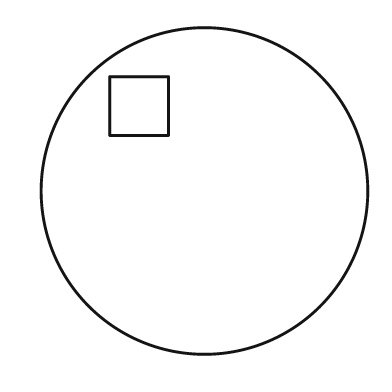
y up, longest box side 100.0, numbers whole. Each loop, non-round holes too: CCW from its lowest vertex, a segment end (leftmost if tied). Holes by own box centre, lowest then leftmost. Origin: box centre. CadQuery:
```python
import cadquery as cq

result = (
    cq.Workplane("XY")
    .moveTo(0.0, 0.0)
    .circle(50.0)
    .moveTo(-29.0, 17.0)
    .lineTo(-11.0, 17.0)
    .lineTo(-11.0, 35.0)
    .lineTo(-29.0, 35.0)
    .close()
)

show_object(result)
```